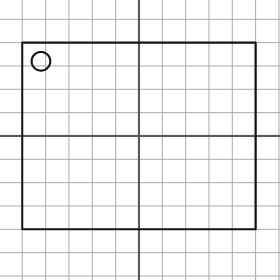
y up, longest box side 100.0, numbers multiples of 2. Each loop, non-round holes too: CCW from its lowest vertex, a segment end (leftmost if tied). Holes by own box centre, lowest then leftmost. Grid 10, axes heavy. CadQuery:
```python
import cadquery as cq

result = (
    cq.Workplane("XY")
    .moveTo(-50.0, -40.0)
    .lineTo(50.0, -40.0)
    .lineTo(50.0, 40.0)
    .lineTo(-50.0, 40.0)
    .close()
    .moveTo(-42.0, 32.0)
    .circle(4.0)
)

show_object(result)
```